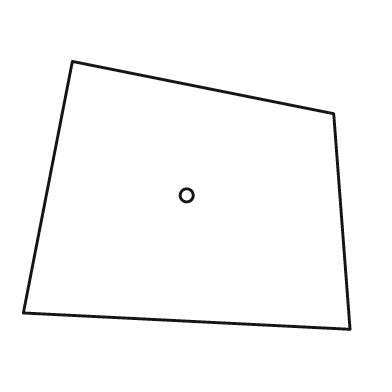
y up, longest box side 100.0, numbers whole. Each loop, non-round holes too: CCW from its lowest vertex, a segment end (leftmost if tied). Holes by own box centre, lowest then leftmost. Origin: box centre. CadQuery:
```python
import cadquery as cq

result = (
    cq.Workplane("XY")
    .moveTo(50.0, -41.0)
    .lineTo(45.0, 25.0)
    .lineTo(-35.0, 41.0)
    .lineTo(-50.0, -36.0)
    .close()
    .moveTo(0.0, 0.0)
    .circle(2.0)
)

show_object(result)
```